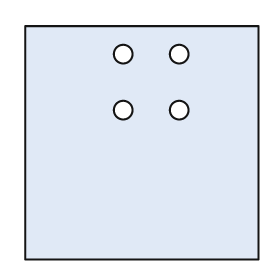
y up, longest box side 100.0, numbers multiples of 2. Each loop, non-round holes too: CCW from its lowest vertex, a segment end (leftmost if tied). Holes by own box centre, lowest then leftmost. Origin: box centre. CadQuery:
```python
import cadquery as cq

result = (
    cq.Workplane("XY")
    .moveTo(-50.0, -50.0)
    .lineTo(50.0, -50.0)
    .lineTo(50.0, 50.0)
    .lineTo(-50.0, 50.0)
    .close()
    .moveTo(-8.0, 14.0)
    .circle(4.0)
    .moveTo(16.0, 14.0)
    .circle(4.0)
    .moveTo(-8.0, 38.0)
    .circle(4.0)
    .moveTo(16.0, 38.0)
    .circle(4.0)
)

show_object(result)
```